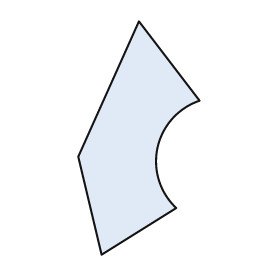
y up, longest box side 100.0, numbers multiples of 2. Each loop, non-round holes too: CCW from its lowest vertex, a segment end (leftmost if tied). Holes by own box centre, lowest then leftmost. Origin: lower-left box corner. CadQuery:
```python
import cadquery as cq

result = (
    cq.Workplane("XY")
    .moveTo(10.0, 0.0)
    .lineTo(42.0, 20.0)
    .threePointArc((34.0, 46.0), (52.0, 66.0))
    .lineTo(26.0, 100.0)
    .lineTo(0.0, 42.0)
    .close()
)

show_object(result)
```